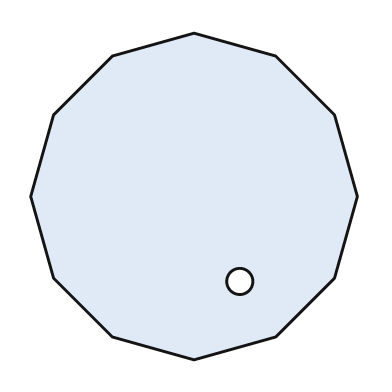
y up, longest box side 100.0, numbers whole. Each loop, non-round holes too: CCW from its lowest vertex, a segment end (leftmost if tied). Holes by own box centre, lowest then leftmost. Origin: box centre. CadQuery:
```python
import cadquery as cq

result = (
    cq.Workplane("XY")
    .moveTo(0.0, -50.0)
    .lineTo(25.0, -43.0)
    .lineTo(43.0, -25.0)
    .lineTo(50.0, 0.0)
    .lineTo(43.0, 25.0)
    .lineTo(25.0, 43.0)
    .lineTo(0.0, 50.0)
    .lineTo(-25.0, 43.0)
    .lineTo(-43.0, 25.0)
    .lineTo(-50.0, 0.0)
    .lineTo(-43.0, -25.0)
    .lineTo(-25.0, -43.0)
    .close()
    .moveTo(14.0, -26.0)
    .circle(4.0)
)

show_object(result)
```